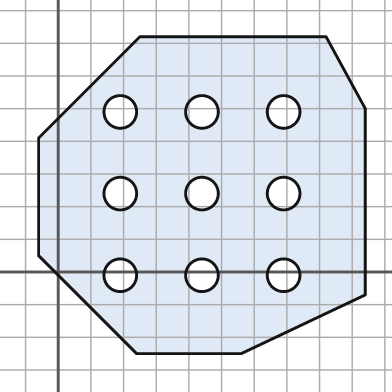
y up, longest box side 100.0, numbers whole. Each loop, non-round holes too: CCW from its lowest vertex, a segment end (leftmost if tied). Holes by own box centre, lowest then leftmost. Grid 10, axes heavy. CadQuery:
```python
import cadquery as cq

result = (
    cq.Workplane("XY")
    .moveTo(24.0, -25.0)
    .lineTo(56.0, -25.0)
    .lineTo(94.0, -7.0)
    .lineTo(94.0, 50.0)
    .lineTo(82.0, 72.0)
    .lineTo(25.0, 72.0)
    .lineTo(-6.0, 41.0)
    .lineTo(-6.0, 5.0)
    .close()
    .moveTo(19.0, -1.0)
    .circle(5.0)
    .moveTo(44.0, -1.0)
    .circle(5.0)
    .moveTo(69.0, -1.0)
    .circle(5.0)
    .moveTo(19.0, 24.0)
    .circle(5.0)
    .moveTo(44.0, 24.0)
    .circle(5.0)
    .moveTo(69.0, 24.0)
    .circle(5.0)
    .moveTo(19.0, 49.0)
    .circle(5.0)
    .moveTo(44.0, 49.0)
    .circle(5.0)
    .moveTo(69.0, 49.0)
    .circle(5.0)
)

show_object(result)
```